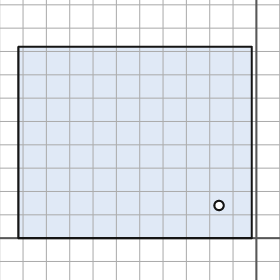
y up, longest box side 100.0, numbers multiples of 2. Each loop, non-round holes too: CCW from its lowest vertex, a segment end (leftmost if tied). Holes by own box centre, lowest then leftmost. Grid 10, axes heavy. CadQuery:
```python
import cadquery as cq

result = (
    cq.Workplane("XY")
    .moveTo(-102.0, 0.0)
    .lineTo(-2.0, 0.0)
    .lineTo(-2.0, 82.0)
    .lineTo(-102.0, 82.0)
    .close()
    .moveTo(-16.0, 14.0)
    .circle(2.0)
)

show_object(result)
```